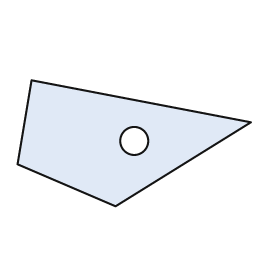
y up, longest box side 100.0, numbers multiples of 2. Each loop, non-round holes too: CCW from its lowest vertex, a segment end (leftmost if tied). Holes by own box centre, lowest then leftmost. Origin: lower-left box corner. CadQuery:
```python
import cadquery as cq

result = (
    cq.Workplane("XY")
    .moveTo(42.0, 0.0)
    .lineTo(100.0, 36.0)
    .lineTo(6.0, 54.0)
    .lineTo(0.0, 18.0)
    .close()
    .moveTo(50.0, 28.0)
    .circle(6.0)
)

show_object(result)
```